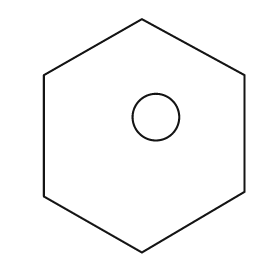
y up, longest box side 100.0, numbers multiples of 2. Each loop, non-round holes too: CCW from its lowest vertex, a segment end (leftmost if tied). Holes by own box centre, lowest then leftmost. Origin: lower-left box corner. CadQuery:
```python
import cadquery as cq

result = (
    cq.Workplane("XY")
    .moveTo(42.0, 0.0)
    .lineTo(86.0, 26.0)
    .lineTo(86.0, 76.0)
    .lineTo(42.0, 100.0)
    .lineTo(0.0, 76.0)
    .lineTo(0.0, 24.0)
    .close()
    .moveTo(48.0, 58.0)
    .circle(10.0)
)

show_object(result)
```